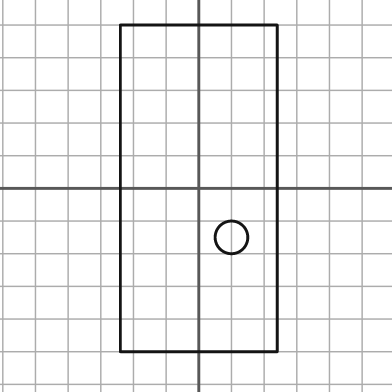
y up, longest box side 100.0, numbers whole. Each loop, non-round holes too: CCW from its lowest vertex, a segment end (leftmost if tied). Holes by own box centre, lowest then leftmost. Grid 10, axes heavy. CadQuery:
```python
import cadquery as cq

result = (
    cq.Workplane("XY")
    .moveTo(-24.0, -50.0)
    .lineTo(24.0, -50.0)
    .lineTo(24.0, 50.0)
    .lineTo(-24.0, 50.0)
    .close()
    .moveTo(10.0, -15.0)
    .circle(5.0)
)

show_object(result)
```